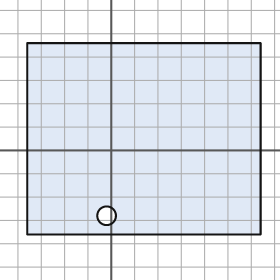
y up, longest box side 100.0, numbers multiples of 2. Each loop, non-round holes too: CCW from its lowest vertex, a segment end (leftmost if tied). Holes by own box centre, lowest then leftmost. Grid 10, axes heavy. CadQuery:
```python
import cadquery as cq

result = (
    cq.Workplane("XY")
    .moveTo(-36.0, -36.0)
    .lineTo(64.0, -36.0)
    .lineTo(64.0, 46.0)
    .lineTo(-36.0, 46.0)
    .close()
    .moveTo(-2.0, -28.0)
    .circle(4.0)
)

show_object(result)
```